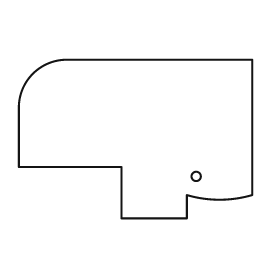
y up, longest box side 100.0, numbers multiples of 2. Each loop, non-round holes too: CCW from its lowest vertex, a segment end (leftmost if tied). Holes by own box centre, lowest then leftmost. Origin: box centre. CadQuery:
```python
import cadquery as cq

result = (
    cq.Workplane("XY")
    .moveTo(-6.0, -34.0)
    .lineTo(22.0, -34.0)
    .lineTo(22.0, -24.0)
    .threePointArc((36.0, -26.0), (50.0, -24.0))
    .lineTo(50.0, 34.0)
    .lineTo(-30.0, 34.0)
    .threePointArc((-44.0, 28.0), (-50.0, 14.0))
    .lineTo(-50.0, -12.0)
    .lineTo(-6.0, -12.0)
    .close()
    .moveTo(26.0, -16.0)
    .circle(2.0)
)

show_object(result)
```